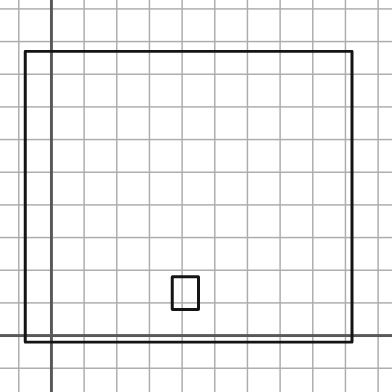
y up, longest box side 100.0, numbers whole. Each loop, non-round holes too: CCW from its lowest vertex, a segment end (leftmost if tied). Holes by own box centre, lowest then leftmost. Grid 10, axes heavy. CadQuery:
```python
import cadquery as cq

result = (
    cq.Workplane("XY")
    .moveTo(-8.0, -2.0)
    .lineTo(92.0, -2.0)
    .lineTo(92.0, 87.0)
    .lineTo(-8.0, 87.0)
    .close()
    .moveTo(37.0, 8.0)
    .lineTo(45.0, 8.0)
    .lineTo(45.0, 18.0)
    .lineTo(37.0, 18.0)
    .close()
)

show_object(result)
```